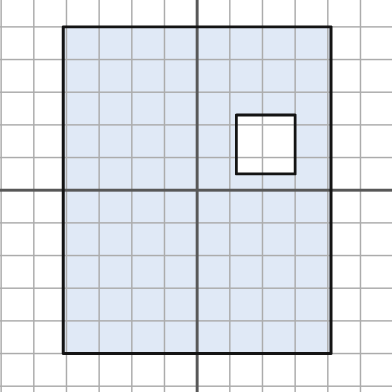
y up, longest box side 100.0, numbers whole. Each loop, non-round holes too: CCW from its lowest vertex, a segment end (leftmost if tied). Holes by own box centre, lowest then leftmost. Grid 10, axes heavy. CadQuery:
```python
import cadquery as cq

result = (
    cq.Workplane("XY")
    .moveTo(-41.0, -50.0)
    .lineTo(41.0, -50.0)
    .lineTo(41.0, 50.0)
    .lineTo(-41.0, 50.0)
    .close()
    .moveTo(12.0, 5.0)
    .lineTo(30.0, 5.0)
    .lineTo(30.0, 23.0)
    .lineTo(12.0, 23.0)
    .close()
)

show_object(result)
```